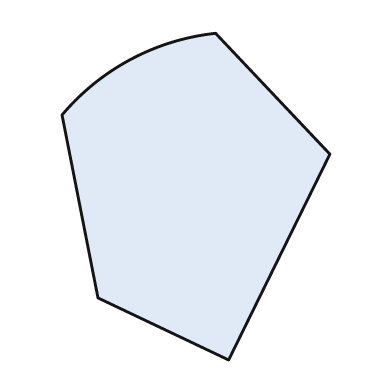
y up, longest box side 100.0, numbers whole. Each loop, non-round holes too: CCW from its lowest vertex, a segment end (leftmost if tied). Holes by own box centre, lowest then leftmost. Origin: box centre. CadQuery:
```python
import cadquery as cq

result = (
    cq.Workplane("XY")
    .moveTo(10.0, -50.0)
    .lineTo(41.0, 13.0)
    .lineTo(6.0, 50.0)
    .threePointArc((-20.0, 42.0), (-41.0, 25.0))
    .lineTo(-30.0, -31.0)
    .close()
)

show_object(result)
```